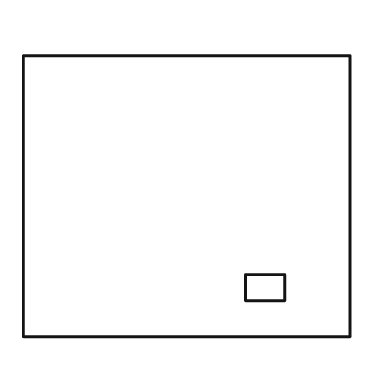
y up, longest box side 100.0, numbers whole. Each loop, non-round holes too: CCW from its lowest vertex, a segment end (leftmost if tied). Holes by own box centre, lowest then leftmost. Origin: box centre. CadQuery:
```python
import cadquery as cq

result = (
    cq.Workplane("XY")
    .moveTo(-50.0, -43.0)
    .lineTo(50.0, -43.0)
    .lineTo(50.0, 43.0)
    .lineTo(-50.0, 43.0)
    .close()
    .moveTo(18.0, -32.0)
    .lineTo(30.0, -32.0)
    .lineTo(30.0, -24.0)
    .lineTo(18.0, -24.0)
    .close()
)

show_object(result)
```